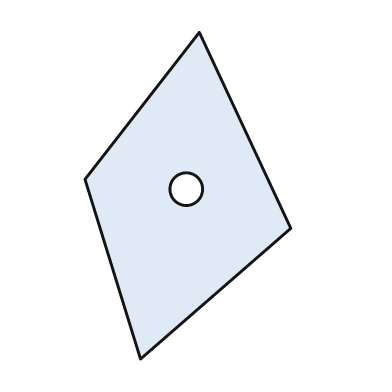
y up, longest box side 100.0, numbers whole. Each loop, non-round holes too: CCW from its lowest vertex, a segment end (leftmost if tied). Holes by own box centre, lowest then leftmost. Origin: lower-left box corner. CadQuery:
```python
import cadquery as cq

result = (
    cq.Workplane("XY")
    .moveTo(17.0, 0.0)
    .lineTo(63.0, 40.0)
    .lineTo(35.0, 100.0)
    .lineTo(0.0, 55.0)
    .close()
    .moveTo(31.0, 52.0)
    .circle(5.0)
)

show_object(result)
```